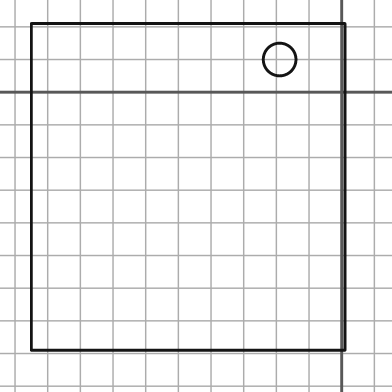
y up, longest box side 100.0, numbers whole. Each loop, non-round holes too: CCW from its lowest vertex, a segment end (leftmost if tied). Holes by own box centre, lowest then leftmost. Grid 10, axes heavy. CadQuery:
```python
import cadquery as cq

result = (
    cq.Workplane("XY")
    .moveTo(-95.0, -79.0)
    .lineTo(1.0, -79.0)
    .lineTo(1.0, 21.0)
    .lineTo(-95.0, 21.0)
    .close()
    .moveTo(-19.0, 10.0)
    .circle(5.0)
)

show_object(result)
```